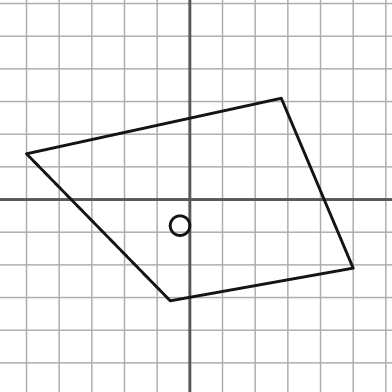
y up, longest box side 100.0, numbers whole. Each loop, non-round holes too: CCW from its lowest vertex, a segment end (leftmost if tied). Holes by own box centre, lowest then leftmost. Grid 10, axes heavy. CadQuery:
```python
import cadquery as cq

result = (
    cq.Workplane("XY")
    .moveTo(-6.0, -31.0)
    .lineTo(50.0, -21.0)
    .lineTo(28.0, 31.0)
    .lineTo(-50.0, 14.0)
    .close()
    .moveTo(-3.0, -8.0)
    .circle(3.0)
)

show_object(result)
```